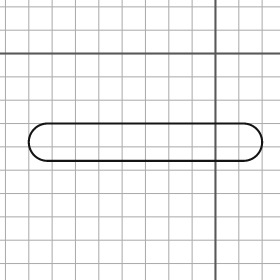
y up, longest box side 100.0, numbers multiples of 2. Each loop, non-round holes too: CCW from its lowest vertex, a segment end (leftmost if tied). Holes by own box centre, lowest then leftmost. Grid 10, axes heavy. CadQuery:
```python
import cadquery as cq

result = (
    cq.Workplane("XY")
    .moveTo(-72.0, -46.0)
    .lineTo(12.0, -46.0)
    .threePointArc((20.0, -38.0), (12.0, -30.0))
    .lineTo(-72.0, -30.0)
    .threePointArc((-80.0, -38.0), (-72.0, -46.0))
    .close()
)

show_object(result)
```